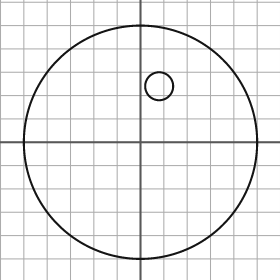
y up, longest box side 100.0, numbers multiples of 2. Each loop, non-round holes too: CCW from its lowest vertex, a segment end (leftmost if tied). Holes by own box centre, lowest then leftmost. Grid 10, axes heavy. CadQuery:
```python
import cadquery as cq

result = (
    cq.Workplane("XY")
    .moveTo(0.0, 0.0)
    .circle(50.0)
    .moveTo(8.0, 24.0)
    .circle(6.0)
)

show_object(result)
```